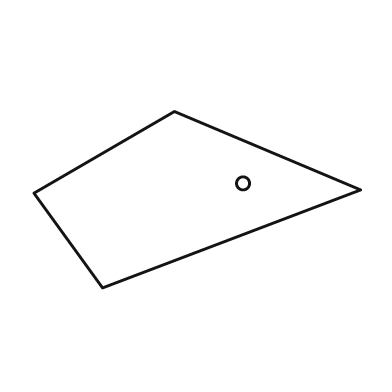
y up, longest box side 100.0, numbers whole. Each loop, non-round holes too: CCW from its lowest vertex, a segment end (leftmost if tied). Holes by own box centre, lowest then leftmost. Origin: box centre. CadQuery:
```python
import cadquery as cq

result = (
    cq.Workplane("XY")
    .moveTo(-29.0, -27.0)
    .lineTo(50.0, 3.0)
    .lineTo(-7.0, 27.0)
    .lineTo(-50.0, 2.0)
    .close()
    .moveTo(14.0, 5.0)
    .circle(2.0)
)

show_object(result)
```